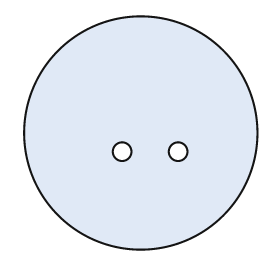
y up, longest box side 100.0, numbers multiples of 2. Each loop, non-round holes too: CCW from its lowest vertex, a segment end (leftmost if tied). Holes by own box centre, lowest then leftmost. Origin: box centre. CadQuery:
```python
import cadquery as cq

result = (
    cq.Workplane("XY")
    .moveTo(0.0, 0.0)
    .circle(50.0)
    .moveTo(-8.0, -8.0)
    .circle(4.0)
    .moveTo(16.0, -8.0)
    .circle(4.0)
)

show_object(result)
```